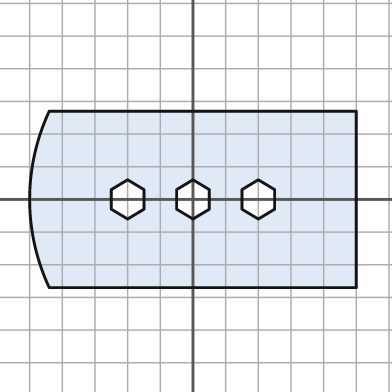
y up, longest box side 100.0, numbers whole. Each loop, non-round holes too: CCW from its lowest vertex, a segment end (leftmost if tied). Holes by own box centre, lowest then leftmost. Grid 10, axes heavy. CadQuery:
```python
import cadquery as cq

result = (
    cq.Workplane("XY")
    .moveTo(-44.0, -27.0)
    .lineTo(50.0, -27.0)
    .lineTo(50.0, 27.0)
    .lineTo(-44.0, 27.0)
    .threePointArc((-50.0, 0.0), (-44.0, -27.0))
    .close()
    .moveTo(-20.0, -6.0)
    .lineTo(-15.0, -3.0)
    .lineTo(-15.0, 3.0)
    .lineTo(-20.0, 6.0)
    .lineTo(-25.0, 3.0)
    .lineTo(-25.0, -3.0)
    .close()
    .moveTo(0.0, -6.0)
    .lineTo(5.0, -3.0)
    .lineTo(5.0, 3.0)
    .lineTo(0.0, 6.0)
    .lineTo(-5.0, 3.0)
    .lineTo(-5.0, -3.0)
    .close()
    .moveTo(20.0, -6.0)
    .lineTo(25.0, -3.0)
    .lineTo(25.0, 3.0)
    .lineTo(20.0, 6.0)
    .lineTo(15.0, 3.0)
    .lineTo(15.0, -3.0)
    .close()
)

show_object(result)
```